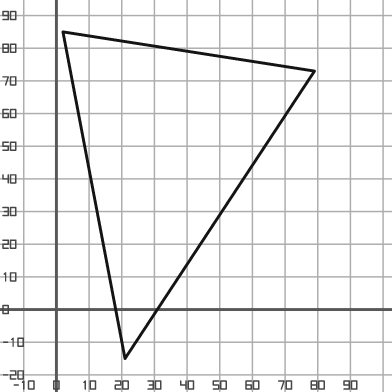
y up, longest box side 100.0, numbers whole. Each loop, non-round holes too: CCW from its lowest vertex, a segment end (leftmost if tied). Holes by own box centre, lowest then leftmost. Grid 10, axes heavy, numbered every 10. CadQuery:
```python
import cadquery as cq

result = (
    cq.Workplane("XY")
    .moveTo(21.0, -15.0)
    .lineTo(79.0, 73.0)
    .lineTo(2.0, 85.0)
    .close()
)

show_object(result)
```